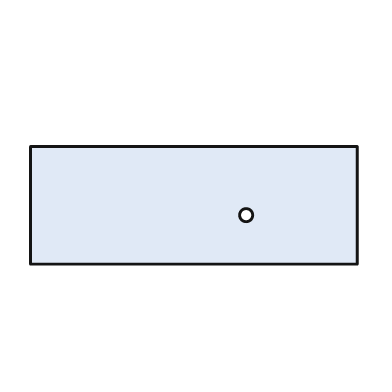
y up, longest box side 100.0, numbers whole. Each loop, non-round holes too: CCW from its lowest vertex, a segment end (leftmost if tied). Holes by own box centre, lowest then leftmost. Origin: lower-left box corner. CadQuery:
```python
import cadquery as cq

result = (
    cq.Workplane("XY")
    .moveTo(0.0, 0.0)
    .lineTo(100.0, 0.0)
    .lineTo(100.0, 36.0)
    .lineTo(0.0, 36.0)
    .close()
    .moveTo(66.0, 15.0)
    .circle(2.0)
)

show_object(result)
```